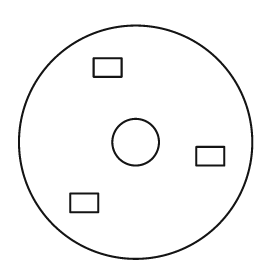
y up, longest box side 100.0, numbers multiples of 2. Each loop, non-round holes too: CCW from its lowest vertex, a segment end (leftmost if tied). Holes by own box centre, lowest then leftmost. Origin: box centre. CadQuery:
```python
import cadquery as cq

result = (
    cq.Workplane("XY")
    .moveTo(0.0, 0.0)
    .circle(50.0)
    .moveTo(-28.0, -30.0)
    .lineTo(-16.0, -30.0)
    .lineTo(-16.0, -22.0)
    .lineTo(-28.0, -22.0)
    .close()
    .moveTo(26.0, -10.0)
    .lineTo(38.0, -10.0)
    .lineTo(38.0, -2.0)
    .lineTo(26.0, -2.0)
    .close()
    .moveTo(0.0, 0.0)
    .circle(10.0)
    .moveTo(-18.0, 28.0)
    .lineTo(-6.0, 28.0)
    .lineTo(-6.0, 36.0)
    .lineTo(-18.0, 36.0)
    .close()
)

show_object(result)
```